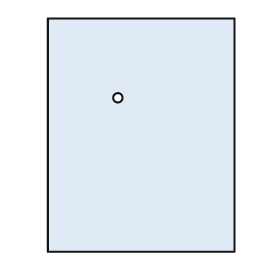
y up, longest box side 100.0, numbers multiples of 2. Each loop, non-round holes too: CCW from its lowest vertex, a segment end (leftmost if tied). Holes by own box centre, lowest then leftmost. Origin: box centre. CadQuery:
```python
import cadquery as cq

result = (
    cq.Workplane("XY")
    .moveTo(-40.0, -50.0)
    .lineTo(40.0, -50.0)
    .lineTo(40.0, 50.0)
    .lineTo(-40.0, 50.0)
    .close()
    .moveTo(-10.0, 16.0)
    .circle(2.0)
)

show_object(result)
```